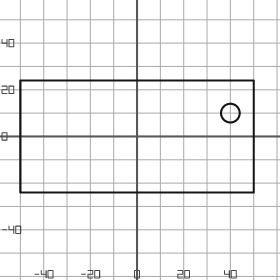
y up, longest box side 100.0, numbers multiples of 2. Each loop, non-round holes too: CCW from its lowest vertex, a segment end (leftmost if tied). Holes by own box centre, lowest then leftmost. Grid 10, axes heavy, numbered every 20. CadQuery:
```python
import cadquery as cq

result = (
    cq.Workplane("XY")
    .moveTo(-50.0, -24.0)
    .lineTo(50.0, -24.0)
    .lineTo(50.0, 24.0)
    .lineTo(-50.0, 24.0)
    .close()
    .moveTo(40.0, 10.0)
    .circle(4.0)
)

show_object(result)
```